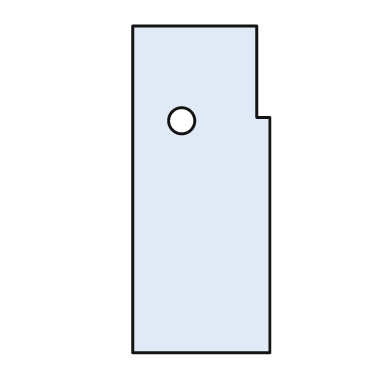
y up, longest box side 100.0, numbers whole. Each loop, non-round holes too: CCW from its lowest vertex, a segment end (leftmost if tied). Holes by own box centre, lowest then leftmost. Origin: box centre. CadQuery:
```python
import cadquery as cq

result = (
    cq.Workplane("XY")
    .moveTo(-21.0, -50.0)
    .lineTo(21.0, -50.0)
    .lineTo(21.0, 22.0)
    .lineTo(17.0, 22.0)
    .lineTo(17.0, 50.0)
    .lineTo(-21.0, 50.0)
    .close()
    .moveTo(-6.0, 21.0)
    .circle(4.0)
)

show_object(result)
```